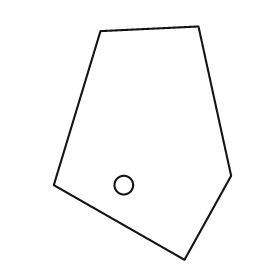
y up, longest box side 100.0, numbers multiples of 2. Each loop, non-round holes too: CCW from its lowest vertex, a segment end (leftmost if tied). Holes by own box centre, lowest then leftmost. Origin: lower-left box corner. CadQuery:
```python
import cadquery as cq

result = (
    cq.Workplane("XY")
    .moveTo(56.0, 0.0)
    .lineTo(76.0, 36.0)
    .lineTo(62.0, 100.0)
    .lineTo(20.0, 98.0)
    .lineTo(0.0, 32.0)
    .close()
    .moveTo(30.0, 32.0)
    .circle(4.0)
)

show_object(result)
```